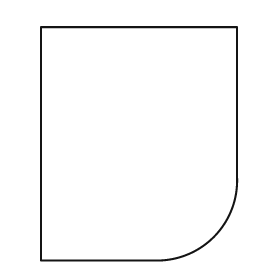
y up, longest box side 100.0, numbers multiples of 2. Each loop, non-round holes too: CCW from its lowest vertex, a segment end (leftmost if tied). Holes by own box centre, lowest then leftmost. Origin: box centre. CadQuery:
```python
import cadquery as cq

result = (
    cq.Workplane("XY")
    .moveTo(-42.0, -50.0)
    .lineTo(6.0, -50.0)
    .threePointArc((32.0, -40.0), (42.0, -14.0))
    .lineTo(42.0, 50.0)
    .lineTo(-42.0, 50.0)
    .close()
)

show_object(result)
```